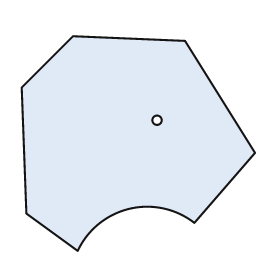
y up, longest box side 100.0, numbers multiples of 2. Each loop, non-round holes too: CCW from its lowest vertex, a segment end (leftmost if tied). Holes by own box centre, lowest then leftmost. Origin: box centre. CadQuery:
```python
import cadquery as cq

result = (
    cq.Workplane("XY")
    .moveTo(-26.0, -46.0)
    .threePointArc((-4.0, -28.0), (24.0, -34.0))
    .lineTo(50.0, -4.0)
    .lineTo(20.0, 44.0)
    .lineTo(-28.0, 46.0)
    .lineTo(-50.0, 24.0)
    .lineTo(-48.0, -30.0)
    .close()
    .moveTo(8.0, 10.0)
    .circle(2.0)
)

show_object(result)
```